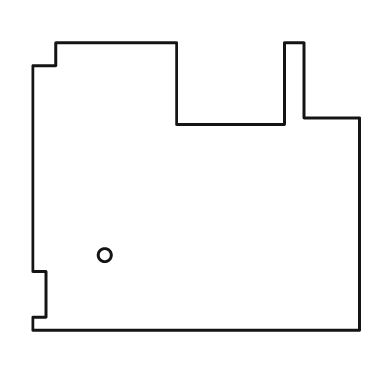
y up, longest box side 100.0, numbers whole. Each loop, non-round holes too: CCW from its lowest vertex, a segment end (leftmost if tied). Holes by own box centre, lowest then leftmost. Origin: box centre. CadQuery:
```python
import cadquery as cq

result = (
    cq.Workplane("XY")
    .moveTo(-50.0, -44.0)
    .lineTo(50.0, -44.0)
    .lineTo(50.0, 21.0)
    .lineTo(33.0, 21.0)
    .lineTo(33.0, 44.0)
    .lineTo(27.0, 44.0)
    .lineTo(27.0, 19.0)
    .lineTo(-6.0, 19.0)
    .lineTo(-6.0, 44.0)
    .lineTo(-43.0, 44.0)
    .lineTo(-43.0, 37.0)
    .lineTo(-50.0, 37.0)
    .lineTo(-50.0, -26.0)
    .lineTo(-46.0, -26.0)
    .lineTo(-46.0, -40.0)
    .lineTo(-50.0, -40.0)
    .close()
    .moveTo(-28.0, -21.0)
    .circle(2.0)
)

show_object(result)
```